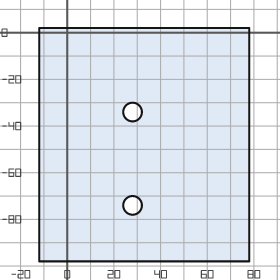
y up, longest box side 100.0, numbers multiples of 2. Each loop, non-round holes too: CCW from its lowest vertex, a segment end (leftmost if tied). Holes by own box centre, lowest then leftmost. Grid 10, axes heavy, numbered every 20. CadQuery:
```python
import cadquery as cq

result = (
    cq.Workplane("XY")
    .moveTo(-12.0, -98.0)
    .lineTo(78.0, -98.0)
    .lineTo(78.0, 2.0)
    .lineTo(-12.0, 2.0)
    .close()
    .moveTo(28.0, -74.0)
    .circle(4.0)
    .moveTo(28.0, -34.0)
    .circle(4.0)
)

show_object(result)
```